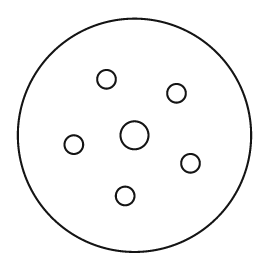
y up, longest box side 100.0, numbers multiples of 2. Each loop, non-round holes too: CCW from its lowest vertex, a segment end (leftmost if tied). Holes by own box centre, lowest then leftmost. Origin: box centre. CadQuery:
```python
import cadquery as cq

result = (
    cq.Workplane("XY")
    .moveTo(0.0, 0.0)
    .circle(50.0)
    .moveTo(-4.0, -26.0)
    .circle(4.0)
    .moveTo(24.0, -12.0)
    .circle(4.0)
    .moveTo(-26.0, -4.0)
    .circle(4.0)
    .moveTo(0.0, 0.0)
    .circle(6.0)
    .moveTo(18.0, 18.0)
    .circle(4.0)
    .moveTo(-12.0, 24.0)
    .circle(4.0)
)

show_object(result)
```